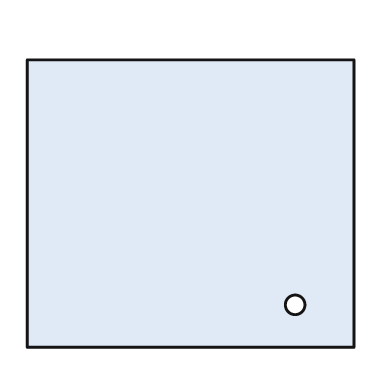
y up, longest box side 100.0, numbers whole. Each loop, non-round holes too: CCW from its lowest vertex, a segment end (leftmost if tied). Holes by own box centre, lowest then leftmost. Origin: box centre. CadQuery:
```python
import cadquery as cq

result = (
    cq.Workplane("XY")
    .moveTo(-50.0, -44.0)
    .lineTo(50.0, -44.0)
    .lineTo(50.0, 44.0)
    .lineTo(-50.0, 44.0)
    .close()
    .moveTo(32.0, -31.0)
    .circle(3.0)
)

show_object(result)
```